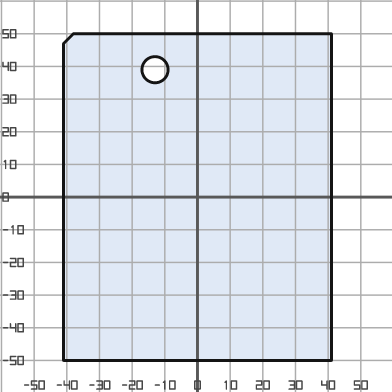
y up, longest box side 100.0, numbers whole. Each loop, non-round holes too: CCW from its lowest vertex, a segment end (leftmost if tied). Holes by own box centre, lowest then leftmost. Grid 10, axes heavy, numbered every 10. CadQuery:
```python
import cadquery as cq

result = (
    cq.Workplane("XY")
    .moveTo(-41.0, -50.0)
    .lineTo(41.0, -50.0)
    .lineTo(41.0, 50.0)
    .lineTo(-38.0, 50.0)
    .lineTo(-41.0, 47.0)
    .close()
    .moveTo(-13.0, 39.0)
    .circle(4.0)
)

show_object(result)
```